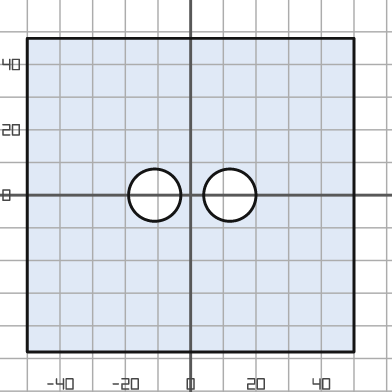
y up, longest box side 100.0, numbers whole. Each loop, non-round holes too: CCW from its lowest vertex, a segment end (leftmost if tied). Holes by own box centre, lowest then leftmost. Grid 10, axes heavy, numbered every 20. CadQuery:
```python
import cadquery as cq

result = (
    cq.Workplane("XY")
    .moveTo(-50.0, -48.0)
    .lineTo(50.0, -48.0)
    .lineTo(50.0, 48.0)
    .lineTo(-50.0, 48.0)
    .close()
    .moveTo(-11.0, 0.0)
    .circle(8.0)
    .moveTo(12.0, 0.0)
    .circle(8.0)
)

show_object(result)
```